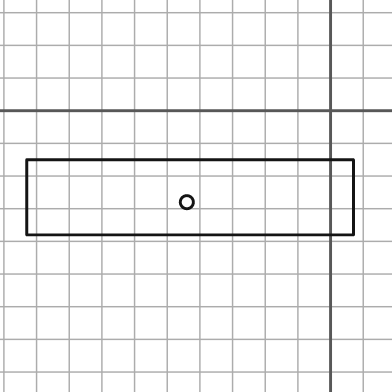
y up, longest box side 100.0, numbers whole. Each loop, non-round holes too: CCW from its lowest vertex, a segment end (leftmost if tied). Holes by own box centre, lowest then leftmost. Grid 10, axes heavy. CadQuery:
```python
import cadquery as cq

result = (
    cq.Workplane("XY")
    .moveTo(-93.0, -38.0)
    .lineTo(7.0, -38.0)
    .lineTo(7.0, -15.0)
    .lineTo(-93.0, -15.0)
    .close()
    .moveTo(-44.0, -28.0)
    .circle(2.0)
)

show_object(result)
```